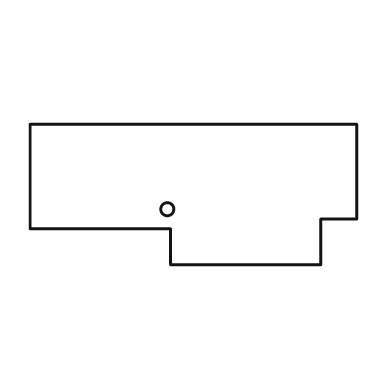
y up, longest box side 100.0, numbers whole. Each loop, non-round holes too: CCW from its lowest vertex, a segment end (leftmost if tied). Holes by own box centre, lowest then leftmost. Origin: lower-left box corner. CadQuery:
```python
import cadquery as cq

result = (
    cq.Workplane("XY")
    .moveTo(43.0, 0.0)
    .lineTo(89.0, 0.0)
    .lineTo(89.0, 14.0)
    .lineTo(100.0, 14.0)
    .lineTo(100.0, 43.0)
    .lineTo(0.0, 43.0)
    .lineTo(0.0, 11.0)
    .lineTo(43.0, 11.0)
    .close()
    .moveTo(42.0, 17.0)
    .circle(2.0)
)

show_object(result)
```